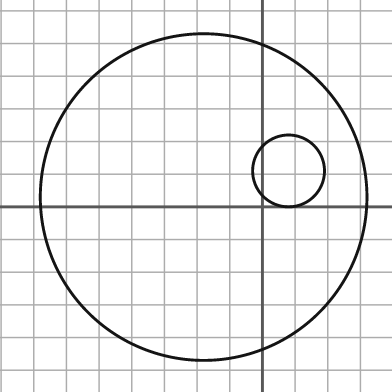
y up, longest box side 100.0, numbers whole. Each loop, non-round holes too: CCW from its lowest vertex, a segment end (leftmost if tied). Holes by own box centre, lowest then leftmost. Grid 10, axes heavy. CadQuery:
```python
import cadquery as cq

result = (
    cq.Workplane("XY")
    .moveTo(-18.0, 3.0)
    .circle(50.0)
    .moveTo(8.0, 11.0)
    .circle(11.0)
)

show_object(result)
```